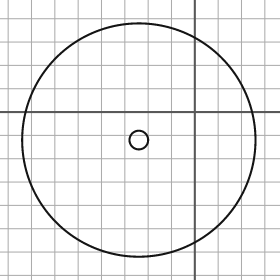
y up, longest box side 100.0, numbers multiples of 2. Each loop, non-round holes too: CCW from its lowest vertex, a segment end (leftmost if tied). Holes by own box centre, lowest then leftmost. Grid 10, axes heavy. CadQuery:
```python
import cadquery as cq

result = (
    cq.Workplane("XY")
    .moveTo(-24.0, -12.0)
    .circle(50.0)
    .moveTo(-24.0, -12.0)
    .circle(4.0)
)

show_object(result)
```